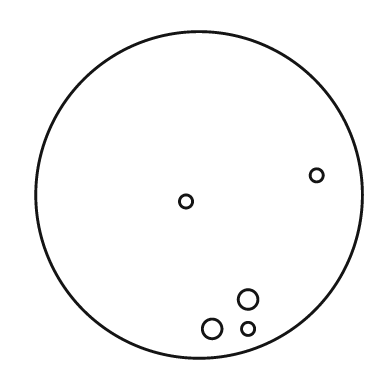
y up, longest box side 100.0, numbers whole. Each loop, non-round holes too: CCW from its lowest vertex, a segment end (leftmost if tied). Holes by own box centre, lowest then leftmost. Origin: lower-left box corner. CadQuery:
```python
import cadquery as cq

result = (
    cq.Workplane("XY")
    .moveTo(50.0, 50.0)
    .circle(50.0)
    .moveTo(54.0, 9.0)
    .circle(3.0)
    .moveTo(65.0, 9.0)
    .circle(2.0)
    .moveTo(65.0, 18.0)
    .circle(3.0)
    .moveTo(46.0, 48.0)
    .circle(2.0)
    .moveTo(86.0, 56.0)
    .circle(2.0)
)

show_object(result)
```